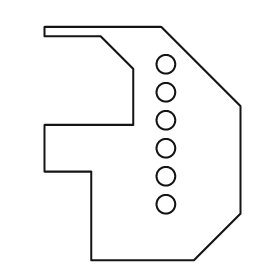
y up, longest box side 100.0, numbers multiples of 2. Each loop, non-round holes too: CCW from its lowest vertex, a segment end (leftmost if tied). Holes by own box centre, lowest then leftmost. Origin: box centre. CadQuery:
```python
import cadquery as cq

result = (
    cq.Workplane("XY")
    .moveTo(-22.0, -50.0)
    .lineTo(22.0, -50.0)
    .lineTo(42.0, -30.0)
    .lineTo(42.0, 16.0)
    .lineTo(8.0, 50.0)
    .lineTo(-42.0, 50.0)
    .lineTo(-42.0, 46.0)
    .lineTo(-18.0, 46.0)
    .lineTo(-4.0, 32.0)
    .lineTo(-4.0, 8.0)
    .lineTo(-42.0, 8.0)
    .lineTo(-42.0, -12.0)
    .lineTo(-22.0, -12.0)
    .close()
    .moveTo(10.0, -26.0)
    .circle(4.0)
    .moveTo(10.0, -14.0)
    .circle(4.0)
    .moveTo(10.0, -2.0)
    .circle(4.0)
    .moveTo(10.0, 10.0)
    .circle(4.0)
    .moveTo(10.0, 22.0)
    .circle(4.0)
    .moveTo(10.0, 34.0)
    .circle(4.0)
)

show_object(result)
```